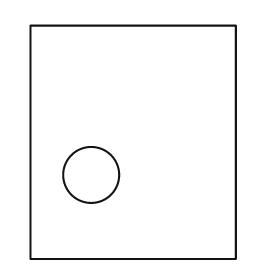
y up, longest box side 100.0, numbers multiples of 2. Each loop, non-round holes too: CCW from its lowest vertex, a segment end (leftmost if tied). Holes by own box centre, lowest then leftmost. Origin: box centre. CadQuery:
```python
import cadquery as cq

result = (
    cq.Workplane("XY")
    .moveTo(-44.0, -50.0)
    .lineTo(44.0, -50.0)
    .lineTo(44.0, 50.0)
    .lineTo(-44.0, 50.0)
    .close()
    .moveTo(-18.0, -14.0)
    .circle(12.0)
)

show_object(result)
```